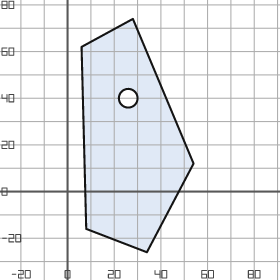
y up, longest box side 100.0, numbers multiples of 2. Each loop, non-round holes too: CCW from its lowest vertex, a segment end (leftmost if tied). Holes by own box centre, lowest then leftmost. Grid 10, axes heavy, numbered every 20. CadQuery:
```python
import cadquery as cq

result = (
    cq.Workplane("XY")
    .moveTo(34.0, -26.0)
    .lineTo(54.0, 12.0)
    .lineTo(28.0, 74.0)
    .lineTo(6.0, 62.0)
    .lineTo(8.0, -16.0)
    .close()
    .moveTo(26.0, 40.0)
    .circle(4.0)
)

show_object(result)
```